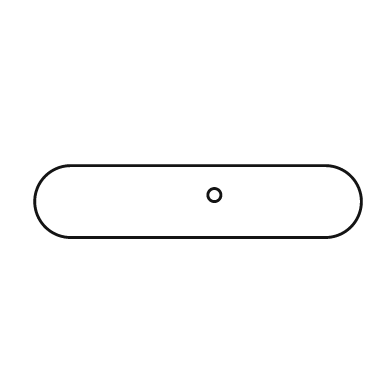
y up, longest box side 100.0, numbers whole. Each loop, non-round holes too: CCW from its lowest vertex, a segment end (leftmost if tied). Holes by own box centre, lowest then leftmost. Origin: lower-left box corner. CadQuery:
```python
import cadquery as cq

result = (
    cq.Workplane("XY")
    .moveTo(11.0, 0.0)
    .lineTo(89.0, 0.0)
    .threePointArc((100.0, 11.0), (89.0, 22.0))
    .lineTo(11.0, 22.0)
    .threePointArc((0.0, 11.0), (11.0, 0.0))
    .close()
    .moveTo(55.0, 13.0)
    .circle(2.0)
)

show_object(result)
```